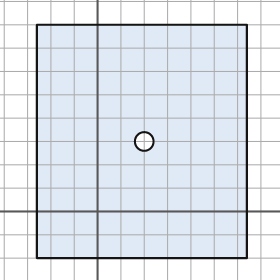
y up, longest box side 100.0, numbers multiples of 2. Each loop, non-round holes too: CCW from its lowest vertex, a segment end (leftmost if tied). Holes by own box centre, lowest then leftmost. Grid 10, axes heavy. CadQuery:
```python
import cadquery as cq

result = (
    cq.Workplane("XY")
    .moveTo(-26.0, -20.0)
    .lineTo(64.0, -20.0)
    .lineTo(64.0, 80.0)
    .lineTo(-26.0, 80.0)
    .close()
    .moveTo(20.0, 30.0)
    .circle(4.0)
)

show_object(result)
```